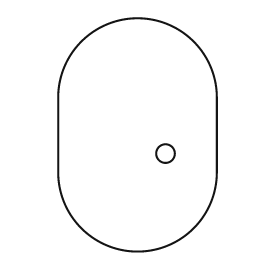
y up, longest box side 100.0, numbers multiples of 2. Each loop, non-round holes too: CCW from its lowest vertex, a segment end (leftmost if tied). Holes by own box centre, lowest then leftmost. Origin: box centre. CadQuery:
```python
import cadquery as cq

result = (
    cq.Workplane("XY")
    .moveTo(-34.0, -16.0)
    .threePointArc((0.0, -50.0), (34.0, -16.0))
    .lineTo(34.0, 16.0)
    .threePointArc((0.0, 50.0), (-34.0, 16.0))
    .close()
    .moveTo(12.0, -8.0)
    .circle(4.0)
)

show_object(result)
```